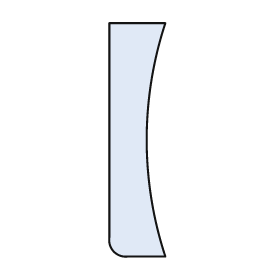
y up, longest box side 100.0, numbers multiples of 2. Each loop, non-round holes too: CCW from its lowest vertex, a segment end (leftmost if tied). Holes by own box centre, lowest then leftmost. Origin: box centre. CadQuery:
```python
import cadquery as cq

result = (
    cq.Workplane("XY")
    .moveTo(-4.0, -50.0)
    .lineTo(12.0, -50.0)
    .threePointArc((4.0, 0.0), (12.0, 50.0))
    .lineTo(-12.0, 50.0)
    .lineTo(-12.0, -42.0)
    .threePointArc((-10.0, -48.0), (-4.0, -50.0))
    .close()
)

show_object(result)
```